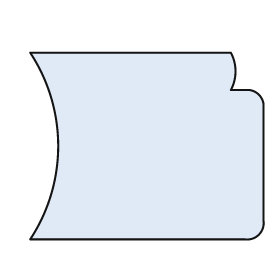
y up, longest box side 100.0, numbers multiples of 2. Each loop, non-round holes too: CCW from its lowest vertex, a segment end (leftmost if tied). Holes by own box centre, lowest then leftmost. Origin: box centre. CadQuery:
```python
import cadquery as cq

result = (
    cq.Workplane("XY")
    .moveTo(-50.0, -40.0)
    .lineTo(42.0, -40.0)
    .threePointArc((48.0, -38.0), (50.0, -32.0))
    .lineTo(50.0, 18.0)
    .threePointArc((48.0, 22.0), (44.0, 24.0))
    .lineTo(36.0, 24.0)
    .threePointArc((38.0, 32.0), (36.0, 40.0))
    .lineTo(-50.0, 40.0)
    .threePointArc((-38.0, 0.0), (-50.0, -40.0))
    .close()
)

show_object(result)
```